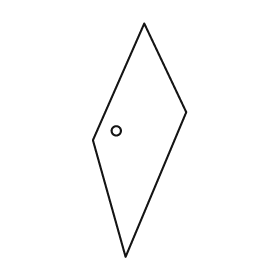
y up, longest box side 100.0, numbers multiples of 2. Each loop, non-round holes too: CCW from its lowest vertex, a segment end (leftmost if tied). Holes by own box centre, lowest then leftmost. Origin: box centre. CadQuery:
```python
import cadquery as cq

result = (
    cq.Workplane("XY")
    .moveTo(-6.0, -50.0)
    .lineTo(20.0, 12.0)
    .lineTo(2.0, 50.0)
    .lineTo(-20.0, 0.0)
    .close()
    .moveTo(-10.0, 4.0)
    .circle(2.0)
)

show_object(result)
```